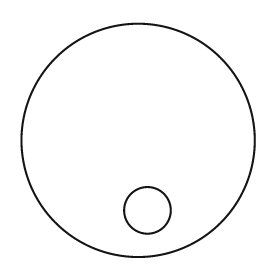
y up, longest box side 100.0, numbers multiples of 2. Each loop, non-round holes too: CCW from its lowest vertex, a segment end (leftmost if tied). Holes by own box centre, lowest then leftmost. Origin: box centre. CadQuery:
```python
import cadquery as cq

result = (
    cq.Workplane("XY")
    .moveTo(0.0, 0.0)
    .circle(50.0)
    .moveTo(4.0, -30.0)
    .circle(10.0)
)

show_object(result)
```